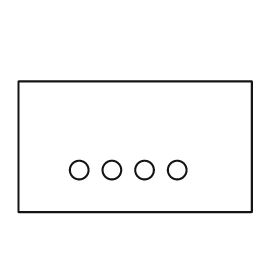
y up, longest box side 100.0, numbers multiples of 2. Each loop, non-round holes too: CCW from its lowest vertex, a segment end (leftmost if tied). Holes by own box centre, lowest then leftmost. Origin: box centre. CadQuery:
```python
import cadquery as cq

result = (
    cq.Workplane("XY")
    .moveTo(-50.0, -28.0)
    .lineTo(50.0, -28.0)
    .lineTo(50.0, 28.0)
    .lineTo(-50.0, 28.0)
    .close()
    .moveTo(-24.0, -10.0)
    .circle(4.0)
    .moveTo(-10.0, -10.0)
    .circle(4.0)
    .moveTo(4.0, -10.0)
    .circle(4.0)
    .moveTo(18.0, -10.0)
    .circle(4.0)
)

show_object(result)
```